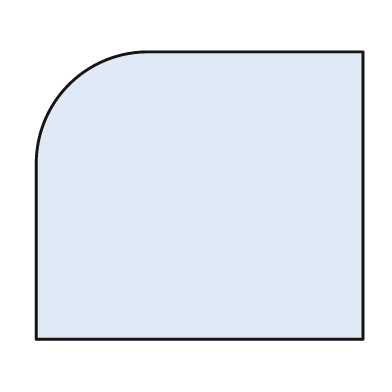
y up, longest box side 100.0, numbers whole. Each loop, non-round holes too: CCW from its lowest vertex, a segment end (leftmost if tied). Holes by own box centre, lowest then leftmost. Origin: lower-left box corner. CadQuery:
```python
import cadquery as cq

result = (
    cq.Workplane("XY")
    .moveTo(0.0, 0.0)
    .lineTo(100.0, 0.0)
    .lineTo(100.0, 88.0)
    .lineTo(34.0, 88.0)
    .threePointArc((10.0, 78.0), (0.0, 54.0))
    .close()
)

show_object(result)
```